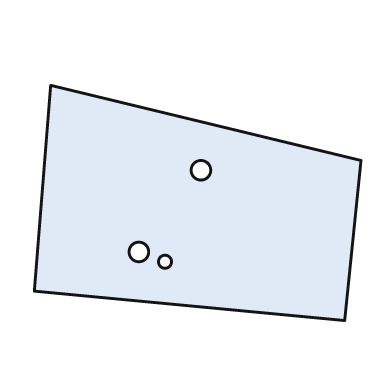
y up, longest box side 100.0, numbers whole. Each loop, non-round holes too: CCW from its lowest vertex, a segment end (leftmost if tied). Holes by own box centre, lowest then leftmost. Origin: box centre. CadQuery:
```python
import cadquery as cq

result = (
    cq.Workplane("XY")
    .moveTo(45.0, -36.0)
    .lineTo(50.0, 13.0)
    .lineTo(-45.0, 36.0)
    .lineTo(-50.0, -27.0)
    .close()
    .moveTo(-10.0, -18.0)
    .circle(2.0)
    .moveTo(-18.0, -15.0)
    .circle(3.0)
    .moveTo(1.0, 10.0)
    .circle(3.0)
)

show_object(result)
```